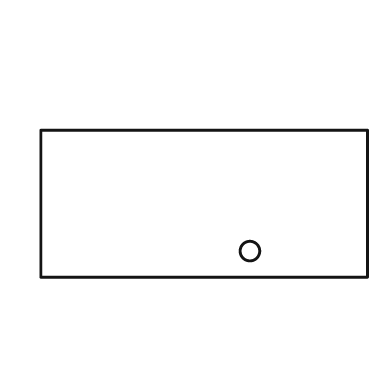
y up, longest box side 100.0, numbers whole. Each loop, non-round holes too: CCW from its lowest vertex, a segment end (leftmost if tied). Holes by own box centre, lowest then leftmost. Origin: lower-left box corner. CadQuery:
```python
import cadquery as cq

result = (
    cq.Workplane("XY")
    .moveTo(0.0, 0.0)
    .lineTo(100.0, 0.0)
    .lineTo(100.0, 45.0)
    .lineTo(0.0, 45.0)
    .close()
    .moveTo(64.0, 8.0)
    .circle(3.0)
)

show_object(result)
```